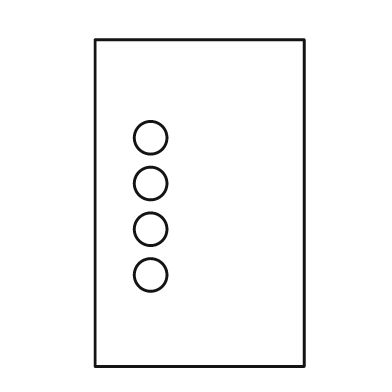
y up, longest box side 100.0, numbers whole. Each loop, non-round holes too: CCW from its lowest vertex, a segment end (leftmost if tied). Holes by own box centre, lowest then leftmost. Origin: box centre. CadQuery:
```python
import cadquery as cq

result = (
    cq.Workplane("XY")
    .moveTo(-32.0, -50.0)
    .lineTo(32.0, -50.0)
    .lineTo(32.0, 50.0)
    .lineTo(-32.0, 50.0)
    .close()
    .moveTo(-15.0, -22.0)
    .circle(5.0)
    .moveTo(-15.0, -8.0)
    .circle(5.0)
    .moveTo(-15.0, 6.0)
    .circle(5.0)
    .moveTo(-15.0, 20.0)
    .circle(5.0)
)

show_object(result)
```